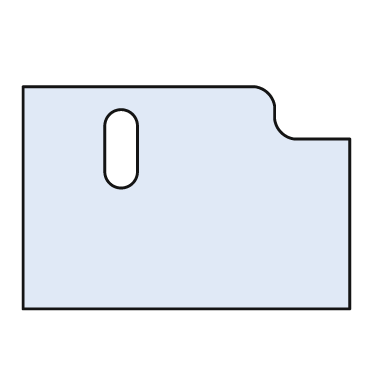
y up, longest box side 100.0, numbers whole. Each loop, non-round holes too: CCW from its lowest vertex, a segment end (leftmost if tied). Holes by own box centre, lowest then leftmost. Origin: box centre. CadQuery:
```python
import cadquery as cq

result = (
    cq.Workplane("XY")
    .moveTo(-50.0, -34.0)
    .lineTo(50.0, -34.0)
    .lineTo(50.0, 18.0)
    .lineTo(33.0, 18.0)
    .threePointArc((29.0, 20.0), (27.0, 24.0))
    .lineTo(27.0, 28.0)
    .threePointArc((25.0, 32.0), (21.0, 34.0))
    .lineTo(-50.0, 34.0)
    .close()
    .moveTo(-25.0, 8.0)
    .threePointArc((-20.0, 3.0), (-15.0, 8.0))
    .lineTo(-15.0, 22.0)
    .threePointArc((-20.0, 27.0), (-25.0, 22.0))
    .close()
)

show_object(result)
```